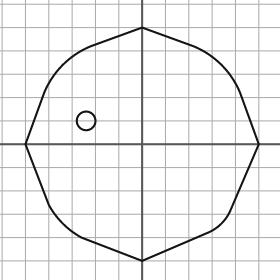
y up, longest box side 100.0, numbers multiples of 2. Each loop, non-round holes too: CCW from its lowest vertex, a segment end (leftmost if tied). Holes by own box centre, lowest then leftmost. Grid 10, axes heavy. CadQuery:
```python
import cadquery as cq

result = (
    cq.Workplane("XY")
    .moveTo(0.0, -50.0)
    .lineTo(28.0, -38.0)
    .threePointArc((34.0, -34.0), (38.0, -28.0))
    .lineTo(50.0, 0.0)
    .lineTo(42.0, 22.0)
    .threePointArc((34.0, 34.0), (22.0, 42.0))
    .lineTo(0.0, 50.0)
    .lineTo(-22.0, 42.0)
    .threePointArc((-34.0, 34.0), (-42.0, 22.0))
    .lineTo(-50.0, 0.0)
    .lineTo(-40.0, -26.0)
    .threePointArc((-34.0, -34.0), (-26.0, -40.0))
    .close()
    .moveTo(-24.0, 10.0)
    .circle(4.0)
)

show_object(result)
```